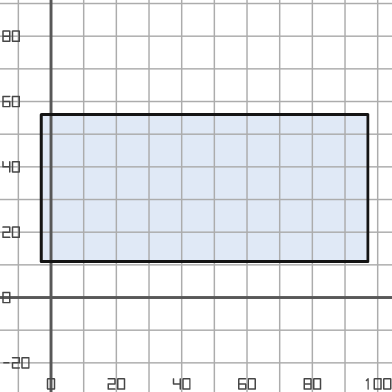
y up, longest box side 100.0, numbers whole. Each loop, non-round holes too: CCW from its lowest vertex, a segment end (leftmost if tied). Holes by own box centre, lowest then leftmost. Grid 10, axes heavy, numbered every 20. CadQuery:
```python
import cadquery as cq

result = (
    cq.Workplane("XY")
    .moveTo(-3.0, 11.0)
    .lineTo(97.0, 11.0)
    .lineTo(97.0, 56.0)
    .lineTo(-3.0, 56.0)
    .close()
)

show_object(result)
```